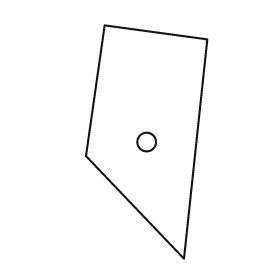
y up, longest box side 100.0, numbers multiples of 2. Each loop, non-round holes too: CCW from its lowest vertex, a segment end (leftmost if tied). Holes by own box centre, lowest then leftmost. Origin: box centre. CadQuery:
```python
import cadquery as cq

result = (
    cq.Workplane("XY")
    .moveTo(16.0, -50.0)
    .lineTo(26.0, 44.0)
    .lineTo(-18.0, 50.0)
    .lineTo(-26.0, -6.0)
    .close()
    .moveTo(0.0, 0.0)
    .circle(4.0)
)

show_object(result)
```